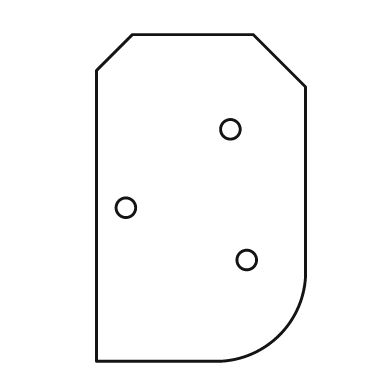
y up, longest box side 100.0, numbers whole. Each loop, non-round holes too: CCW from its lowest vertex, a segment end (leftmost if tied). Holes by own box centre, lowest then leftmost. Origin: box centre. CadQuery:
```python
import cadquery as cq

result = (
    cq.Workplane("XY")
    .moveTo(-32.0, -50.0)
    .lineTo(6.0, -50.0)
    .threePointArc((24.0, -42.0), (32.0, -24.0))
    .lineTo(32.0, 34.0)
    .lineTo(16.0, 50.0)
    .lineTo(-21.0, 50.0)
    .lineTo(-32.0, 39.0)
    .close()
    .moveTo(14.0, -19.0)
    .circle(3.0)
    .moveTo(-23.0, -3.0)
    .circle(3.0)
    .moveTo(9.0, 21.0)
    .circle(3.0)
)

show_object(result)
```